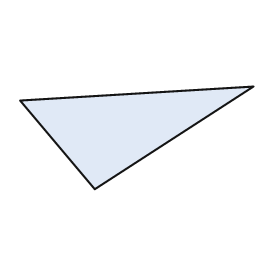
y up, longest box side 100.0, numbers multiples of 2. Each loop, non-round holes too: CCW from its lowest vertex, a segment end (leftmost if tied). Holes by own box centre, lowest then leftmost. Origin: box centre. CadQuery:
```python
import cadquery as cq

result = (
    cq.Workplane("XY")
    .moveTo(-18.0, -22.0)
    .lineTo(50.0, 22.0)
    .lineTo(-50.0, 16.0)
    .close()
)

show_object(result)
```